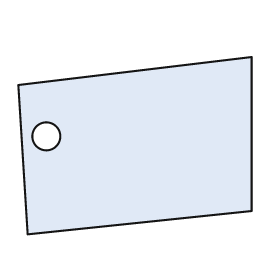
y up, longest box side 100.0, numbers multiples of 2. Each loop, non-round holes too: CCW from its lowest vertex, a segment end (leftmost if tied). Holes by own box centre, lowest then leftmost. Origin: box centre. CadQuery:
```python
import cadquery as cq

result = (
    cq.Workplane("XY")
    .moveTo(-46.0, -38.0)
    .lineTo(50.0, -28.0)
    .lineTo(50.0, 38.0)
    .lineTo(-50.0, 26.0)
    .close()
    .moveTo(-38.0, 4.0)
    .circle(6.0)
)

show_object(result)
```